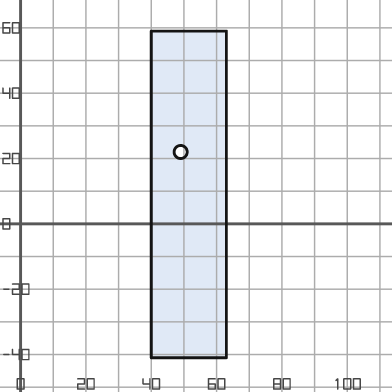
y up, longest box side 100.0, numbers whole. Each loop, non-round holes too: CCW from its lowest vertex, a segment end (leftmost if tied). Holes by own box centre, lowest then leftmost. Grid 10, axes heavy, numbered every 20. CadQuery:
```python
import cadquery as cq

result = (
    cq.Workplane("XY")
    .moveTo(40.0, -41.0)
    .lineTo(63.0, -41.0)
    .lineTo(63.0, 59.0)
    .lineTo(40.0, 59.0)
    .close()
    .moveTo(49.0, 22.0)
    .circle(2.0)
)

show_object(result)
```